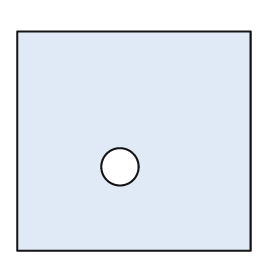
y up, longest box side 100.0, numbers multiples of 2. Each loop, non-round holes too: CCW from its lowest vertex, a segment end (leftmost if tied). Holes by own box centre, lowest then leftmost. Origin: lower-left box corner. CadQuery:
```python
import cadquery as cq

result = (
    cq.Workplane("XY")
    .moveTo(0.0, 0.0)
    .lineTo(100.0, 0.0)
    .lineTo(100.0, 94.0)
    .lineTo(0.0, 94.0)
    .close()
    .moveTo(44.0, 36.0)
    .circle(8.0)
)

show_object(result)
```